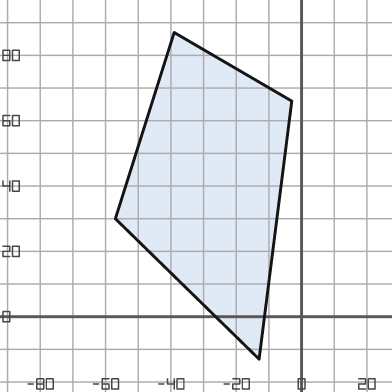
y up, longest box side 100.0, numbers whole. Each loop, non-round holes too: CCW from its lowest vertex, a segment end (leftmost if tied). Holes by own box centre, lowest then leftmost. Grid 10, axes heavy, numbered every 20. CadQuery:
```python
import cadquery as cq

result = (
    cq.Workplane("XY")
    .moveTo(-13.0, -13.0)
    .lineTo(-3.0, 66.0)
    .lineTo(-39.0, 87.0)
    .lineTo(-57.0, 30.0)
    .close()
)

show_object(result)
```